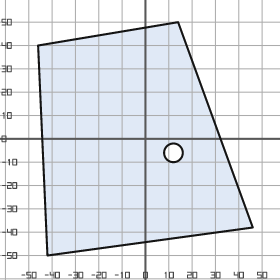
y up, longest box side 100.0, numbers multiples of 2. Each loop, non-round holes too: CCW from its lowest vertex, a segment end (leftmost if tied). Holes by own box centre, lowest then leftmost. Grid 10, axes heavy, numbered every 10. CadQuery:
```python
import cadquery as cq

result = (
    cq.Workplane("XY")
    .moveTo(-42.0, -50.0)
    .lineTo(46.0, -38.0)
    .lineTo(14.0, 50.0)
    .lineTo(-46.0, 40.0)
    .close()
    .moveTo(12.0, -6.0)
    .circle(4.0)
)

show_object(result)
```